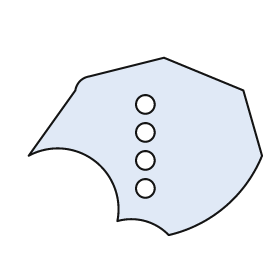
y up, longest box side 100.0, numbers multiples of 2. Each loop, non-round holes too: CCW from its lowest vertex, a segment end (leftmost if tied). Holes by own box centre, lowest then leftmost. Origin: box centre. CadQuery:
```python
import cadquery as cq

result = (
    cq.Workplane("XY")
    .moveTo(10.0, -38.0)
    .threePointArc((34.0, -26.0), (50.0, -4.0))
    .lineTo(42.0, 24.0)
    .lineTo(8.0, 38.0)
    .lineTo(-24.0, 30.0)
    .threePointArc((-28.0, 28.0), (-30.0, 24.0))
    .lineTo(-50.0, -4.0)
    .threePointArc((-22.0, -6.0), (-12.0, -32.0))
    .threePointArc((0.0, -32.0), (10.0, -38.0))
    .close()
    .moveTo(0.0, -18.0)
    .circle(4.0)
    .moveTo(0.0, -6.0)
    .circle(4.0)
    .moveTo(0.0, 6.0)
    .circle(4.0)
    .moveTo(0.0, 18.0)
    .circle(4.0)
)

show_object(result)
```